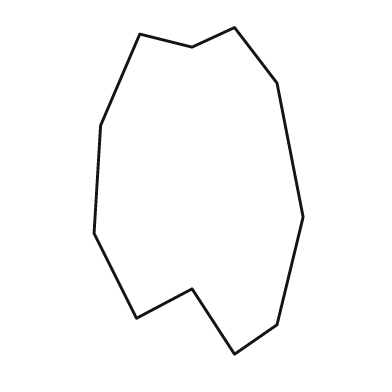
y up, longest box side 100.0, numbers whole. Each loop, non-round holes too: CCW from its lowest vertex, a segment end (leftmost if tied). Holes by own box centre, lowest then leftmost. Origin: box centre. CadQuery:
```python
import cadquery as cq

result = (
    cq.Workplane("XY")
    .moveTo(11.0, -50.0)
    .lineTo(24.0, -41.0)
    .lineTo(32.0, -8.0)
    .lineTo(24.0, 33.0)
    .lineTo(11.0, 50.0)
    .lineTo(-2.0, 44.0)
    .lineTo(-18.0, 48.0)
    .lineTo(-30.0, 20.0)
    .lineTo(-32.0, -13.0)
    .lineTo(-19.0, -39.0)
    .lineTo(-2.0, -30.0)
    .close()
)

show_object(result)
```